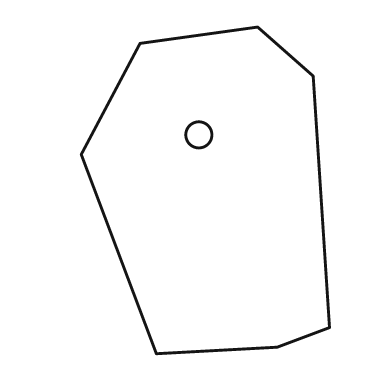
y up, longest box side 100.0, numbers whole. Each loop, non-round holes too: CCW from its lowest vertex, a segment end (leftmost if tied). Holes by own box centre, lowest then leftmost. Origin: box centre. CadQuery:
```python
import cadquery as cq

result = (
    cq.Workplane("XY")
    .moveTo(-15.0, -50.0)
    .lineTo(22.0, -48.0)
    .lineTo(38.0, -42.0)
    .lineTo(33.0, 35.0)
    .lineTo(16.0, 50.0)
    .lineTo(-20.0, 45.0)
    .lineTo(-38.0, 11.0)
    .close()
    .moveTo(-2.0, 17.0)
    .circle(4.0)
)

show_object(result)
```